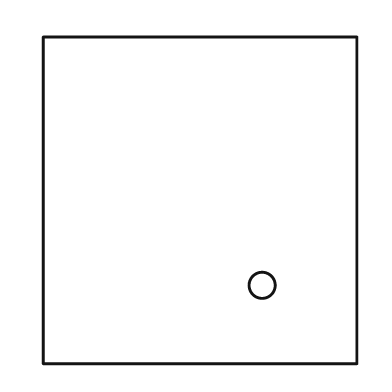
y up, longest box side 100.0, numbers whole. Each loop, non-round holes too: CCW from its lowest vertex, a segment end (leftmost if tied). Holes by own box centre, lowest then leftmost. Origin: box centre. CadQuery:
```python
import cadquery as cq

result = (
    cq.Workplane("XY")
    .moveTo(-48.0, -50.0)
    .lineTo(48.0, -50.0)
    .lineTo(48.0, 50.0)
    .lineTo(-48.0, 50.0)
    .close()
    .moveTo(19.0, -26.0)
    .circle(4.0)
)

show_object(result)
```